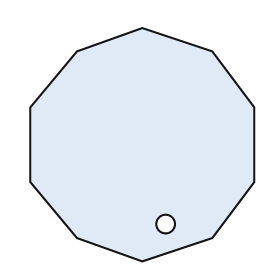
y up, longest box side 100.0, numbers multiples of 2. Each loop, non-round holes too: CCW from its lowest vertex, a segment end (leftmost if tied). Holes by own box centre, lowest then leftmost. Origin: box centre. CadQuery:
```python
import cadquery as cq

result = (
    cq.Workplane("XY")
    .moveTo(0.0, -50.0)
    .lineTo(30.0, -40.0)
    .lineTo(48.0, -16.0)
    .lineTo(48.0, 16.0)
    .lineTo(30.0, 40.0)
    .lineTo(0.0, 50.0)
    .lineTo(-28.0, 40.0)
    .lineTo(-48.0, 16.0)
    .lineTo(-48.0, -16.0)
    .lineTo(-28.0, -40.0)
    .close()
    .moveTo(10.0, -34.0)
    .circle(4.0)
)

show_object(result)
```